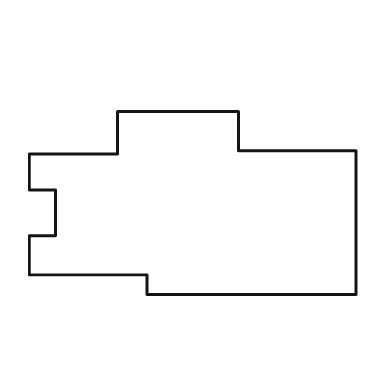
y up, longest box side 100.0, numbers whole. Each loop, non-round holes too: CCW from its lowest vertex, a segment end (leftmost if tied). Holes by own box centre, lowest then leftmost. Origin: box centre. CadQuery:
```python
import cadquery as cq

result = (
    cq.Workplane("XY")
    .moveTo(-14.0, -28.0)
    .lineTo(50.0, -28.0)
    .lineTo(50.0, 16.0)
    .lineTo(14.0, 16.0)
    .lineTo(14.0, 28.0)
    .lineTo(-23.0, 28.0)
    .lineTo(-23.0, 15.0)
    .lineTo(-50.0, 15.0)
    .lineTo(-50.0, 4.0)
    .lineTo(-42.0, 4.0)
    .lineTo(-42.0, -10.0)
    .lineTo(-50.0, -10.0)
    .lineTo(-50.0, -22.0)
    .lineTo(-14.0, -22.0)
    .close()
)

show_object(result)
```